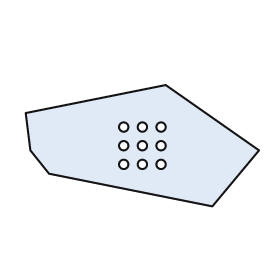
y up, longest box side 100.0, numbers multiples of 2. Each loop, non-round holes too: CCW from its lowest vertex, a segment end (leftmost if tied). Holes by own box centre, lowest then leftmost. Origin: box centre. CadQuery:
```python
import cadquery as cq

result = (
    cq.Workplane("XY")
    .moveTo(30.0, -26.0)
    .lineTo(50.0, -2.0)
    .lineTo(10.0, 26.0)
    .lineTo(-50.0, 14.0)
    .lineTo(-48.0, -2.0)
    .lineTo(-40.0, -12.0)
    .close()
    .moveTo(-8.0, -8.0)
    .circle(2.0)
    .moveTo(0.0, -8.0)
    .circle(2.0)
    .moveTo(8.0, -8.0)
    .circle(2.0)
    .moveTo(-8.0, 0.0)
    .circle(2.0)
    .moveTo(0.0, 0.0)
    .circle(2.0)
    .moveTo(8.0, 0.0)
    .circle(2.0)
    .moveTo(-8.0, 8.0)
    .circle(2.0)
    .moveTo(0.0, 8.0)
    .circle(2.0)
    .moveTo(8.0, 8.0)
    .circle(2.0)
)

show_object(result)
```